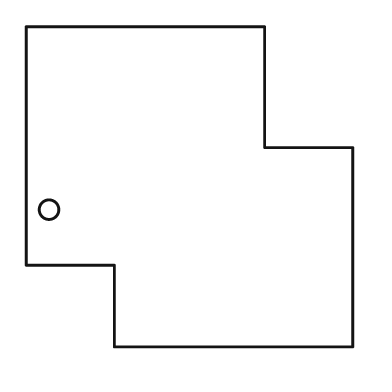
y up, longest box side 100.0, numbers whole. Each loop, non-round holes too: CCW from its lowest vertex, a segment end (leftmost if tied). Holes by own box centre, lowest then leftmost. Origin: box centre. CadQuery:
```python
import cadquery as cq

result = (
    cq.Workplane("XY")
    .moveTo(-23.0, -49.0)
    .lineTo(50.0, -49.0)
    .lineTo(50.0, 12.0)
    .lineTo(23.0, 12.0)
    .lineTo(23.0, 49.0)
    .lineTo(-50.0, 49.0)
    .lineTo(-50.0, -24.0)
    .lineTo(-23.0, -24.0)
    .close()
    .moveTo(-43.0, -7.0)
    .circle(3.0)
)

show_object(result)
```